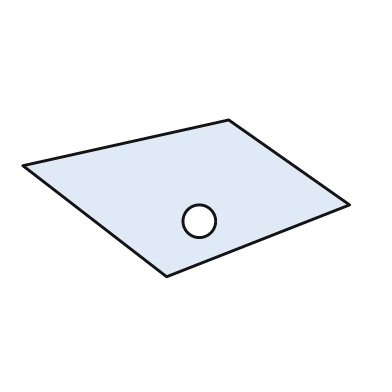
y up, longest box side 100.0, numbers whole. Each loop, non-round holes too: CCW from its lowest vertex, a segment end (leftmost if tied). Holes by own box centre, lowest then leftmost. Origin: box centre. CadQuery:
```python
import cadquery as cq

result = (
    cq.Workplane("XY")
    .moveTo(-6.0, -24.0)
    .lineTo(50.0, -2.0)
    .lineTo(13.0, 24.0)
    .lineTo(-50.0, 10.0)
    .close()
    .moveTo(4.0, -7.0)
    .circle(5.0)
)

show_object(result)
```